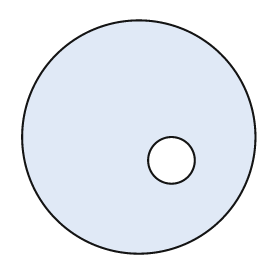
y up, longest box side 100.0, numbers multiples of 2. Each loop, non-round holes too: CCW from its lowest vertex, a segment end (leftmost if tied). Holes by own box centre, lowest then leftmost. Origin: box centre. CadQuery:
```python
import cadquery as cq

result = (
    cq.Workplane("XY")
    .moveTo(0.0, 0.0)
    .circle(50.0)
    .moveTo(14.0, -10.0)
    .circle(10.0)
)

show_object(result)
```